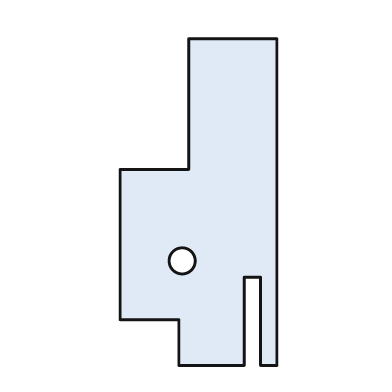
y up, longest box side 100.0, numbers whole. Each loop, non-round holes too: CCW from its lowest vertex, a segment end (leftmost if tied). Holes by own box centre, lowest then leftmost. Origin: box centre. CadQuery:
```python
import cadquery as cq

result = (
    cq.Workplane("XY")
    .moveTo(-6.0, -50.0)
    .lineTo(14.0, -50.0)
    .lineTo(14.0, -23.0)
    .lineTo(19.0, -23.0)
    .lineTo(19.0, -50.0)
    .lineTo(24.0, -50.0)
    .lineTo(24.0, 50.0)
    .lineTo(-3.0, 50.0)
    .lineTo(-3.0, 10.0)
    .lineTo(-24.0, 10.0)
    .lineTo(-24.0, -36.0)
    .lineTo(-6.0, -36.0)
    .close()
    .moveTo(-5.0, -18.0)
    .circle(4.0)
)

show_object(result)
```